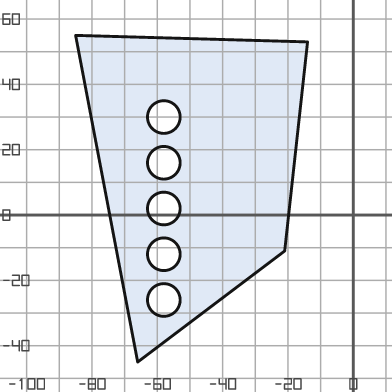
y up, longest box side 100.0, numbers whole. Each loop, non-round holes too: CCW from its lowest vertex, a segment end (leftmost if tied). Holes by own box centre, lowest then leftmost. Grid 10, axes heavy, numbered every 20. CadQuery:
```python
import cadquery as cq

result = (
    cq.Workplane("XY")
    .moveTo(-66.0, -45.0)
    .lineTo(-21.0, -11.0)
    .lineTo(-14.0, 53.0)
    .lineTo(-85.0, 55.0)
    .close()
    .moveTo(-58.0, -26.0)
    .circle(5.0)
    .moveTo(-58.0, -12.0)
    .circle(5.0)
    .moveTo(-58.0, 2.0)
    .circle(5.0)
    .moveTo(-58.0, 16.0)
    .circle(5.0)
    .moveTo(-58.0, 30.0)
    .circle(5.0)
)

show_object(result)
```